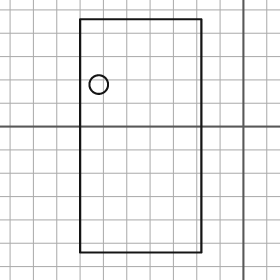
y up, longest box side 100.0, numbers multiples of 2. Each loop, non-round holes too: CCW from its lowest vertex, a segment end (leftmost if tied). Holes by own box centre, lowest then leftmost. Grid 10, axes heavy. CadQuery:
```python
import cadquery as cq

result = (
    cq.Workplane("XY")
    .moveTo(-70.0, -54.0)
    .lineTo(-18.0, -54.0)
    .lineTo(-18.0, 46.0)
    .lineTo(-70.0, 46.0)
    .close()
    .moveTo(-62.0, 18.0)
    .circle(4.0)
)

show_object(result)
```